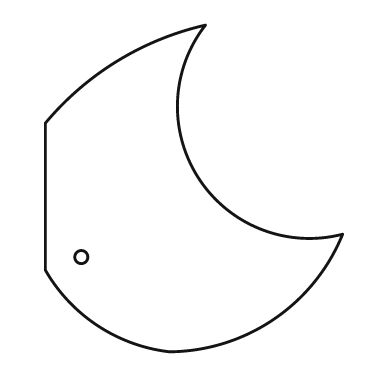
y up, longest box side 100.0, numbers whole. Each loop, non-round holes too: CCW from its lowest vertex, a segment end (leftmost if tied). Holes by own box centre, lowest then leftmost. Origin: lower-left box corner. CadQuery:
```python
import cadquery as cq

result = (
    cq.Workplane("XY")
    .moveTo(38.0, 0.0)
    .threePointArc((70.0, 10.0), (91.0, 36.0))
    .threePointArc((47.0, 53.0), (49.0, 100.0))
    .threePointArc((22.0, 89.0), (0.0, 70.0))
    .lineTo(0.0, 25.0)
    .threePointArc((16.0, 8.0), (38.0, 0.0))
    .close()
    .moveTo(11.0, 29.0)
    .circle(2.0)
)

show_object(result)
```